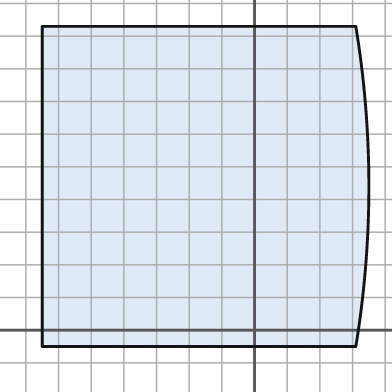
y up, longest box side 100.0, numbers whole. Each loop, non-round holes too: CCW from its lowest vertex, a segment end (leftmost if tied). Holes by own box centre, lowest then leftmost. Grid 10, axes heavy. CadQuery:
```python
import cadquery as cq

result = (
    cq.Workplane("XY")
    .moveTo(-65.0, -5.0)
    .lineTo(31.0, -5.0)
    .threePointArc((35.0, 44.0), (31.0, 93.0))
    .lineTo(-65.0, 93.0)
    .close()
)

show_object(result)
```